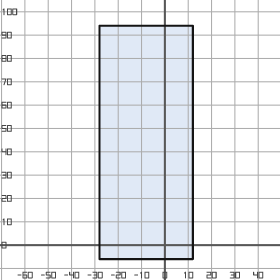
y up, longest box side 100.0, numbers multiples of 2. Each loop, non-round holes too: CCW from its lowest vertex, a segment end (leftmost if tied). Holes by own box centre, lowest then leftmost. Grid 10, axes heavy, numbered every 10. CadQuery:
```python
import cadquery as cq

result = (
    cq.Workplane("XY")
    .moveTo(-28.0, -6.0)
    .lineTo(12.0, -6.0)
    .lineTo(12.0, 94.0)
    .lineTo(-28.0, 94.0)
    .close()
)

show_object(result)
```